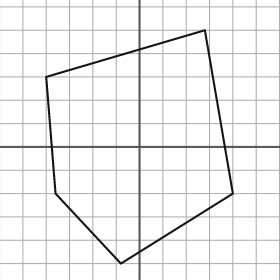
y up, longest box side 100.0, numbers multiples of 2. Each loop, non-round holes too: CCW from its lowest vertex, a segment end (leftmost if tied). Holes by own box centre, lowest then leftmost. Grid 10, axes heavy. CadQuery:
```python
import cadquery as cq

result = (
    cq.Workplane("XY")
    .moveTo(-8.0, -50.0)
    .lineTo(40.0, -20.0)
    .lineTo(28.0, 50.0)
    .lineTo(-40.0, 30.0)
    .lineTo(-36.0, -20.0)
    .close()
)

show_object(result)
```